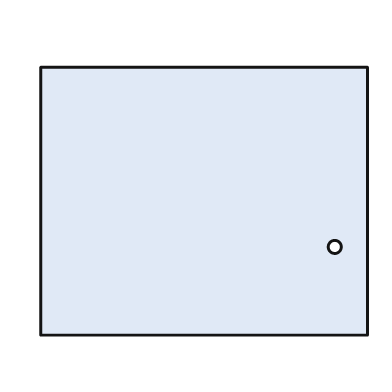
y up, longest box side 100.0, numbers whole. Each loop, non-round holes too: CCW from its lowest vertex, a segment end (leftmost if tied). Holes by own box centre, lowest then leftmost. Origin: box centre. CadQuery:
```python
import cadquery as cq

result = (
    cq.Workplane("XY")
    .moveTo(-50.0, -41.0)
    .lineTo(50.0, -41.0)
    .lineTo(50.0, 41.0)
    .lineTo(-50.0, 41.0)
    .close()
    .moveTo(40.0, -14.0)
    .circle(2.0)
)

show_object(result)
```